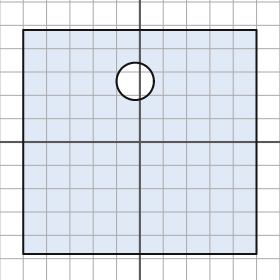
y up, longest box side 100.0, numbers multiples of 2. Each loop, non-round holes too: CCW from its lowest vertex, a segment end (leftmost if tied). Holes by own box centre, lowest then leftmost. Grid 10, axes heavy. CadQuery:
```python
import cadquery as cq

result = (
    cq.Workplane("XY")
    .moveTo(-50.0, -48.0)
    .lineTo(50.0, -48.0)
    .lineTo(50.0, 48.0)
    .lineTo(-50.0, 48.0)
    .close()
    .moveTo(-2.0, 26.0)
    .circle(8.0)
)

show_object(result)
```